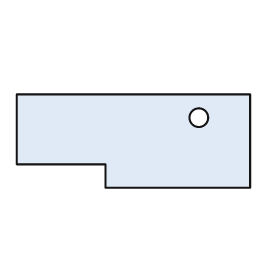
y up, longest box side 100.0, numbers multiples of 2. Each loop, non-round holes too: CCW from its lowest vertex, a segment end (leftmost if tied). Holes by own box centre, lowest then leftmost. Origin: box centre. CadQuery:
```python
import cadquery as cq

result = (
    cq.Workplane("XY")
    .moveTo(-12.0, -20.0)
    .lineTo(50.0, -20.0)
    .lineTo(50.0, 20.0)
    .lineTo(-50.0, 20.0)
    .lineTo(-50.0, -10.0)
    .lineTo(-12.0, -10.0)
    .close()
    .moveTo(28.0, 10.0)
    .circle(4.0)
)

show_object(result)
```